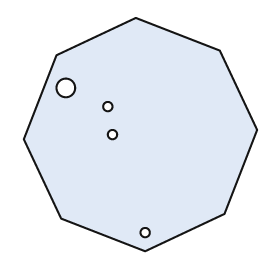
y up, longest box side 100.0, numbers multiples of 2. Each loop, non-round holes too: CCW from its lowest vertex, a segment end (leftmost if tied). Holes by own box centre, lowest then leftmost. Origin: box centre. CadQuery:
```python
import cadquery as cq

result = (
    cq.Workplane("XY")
    .moveTo(2.0, -50.0)
    .lineTo(36.0, -34.0)
    .lineTo(50.0, 2.0)
    .lineTo(34.0, 36.0)
    .lineTo(-2.0, 50.0)
    .lineTo(-36.0, 34.0)
    .lineTo(-50.0, -2.0)
    .lineTo(-34.0, -36.0)
    .close()
    .moveTo(2.0, -42.0)
    .circle(2.0)
    .moveTo(-12.0, 0.0)
    .circle(2.0)
    .moveTo(-14.0, 12.0)
    .circle(2.0)
    .moveTo(-32.0, 20.0)
    .circle(4.0)
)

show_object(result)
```